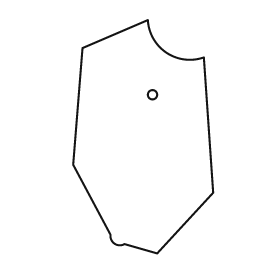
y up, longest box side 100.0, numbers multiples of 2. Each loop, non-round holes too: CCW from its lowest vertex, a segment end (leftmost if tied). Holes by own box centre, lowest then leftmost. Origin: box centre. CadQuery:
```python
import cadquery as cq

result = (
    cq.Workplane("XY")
    .moveTo(6.0, -50.0)
    .lineTo(30.0, -24.0)
    .lineTo(26.0, 34.0)
    .threePointArc((10.0, 36.0), (2.0, 50.0))
    .lineTo(-26.0, 38.0)
    .lineTo(-30.0, -12.0)
    .lineTo(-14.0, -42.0)
    .threePointArc((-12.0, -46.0), (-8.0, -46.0))
    .close()
    .moveTo(4.0, 18.0)
    .circle(2.0)
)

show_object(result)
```